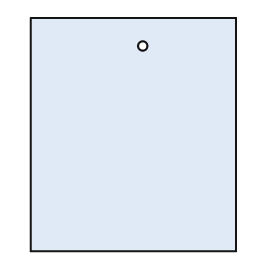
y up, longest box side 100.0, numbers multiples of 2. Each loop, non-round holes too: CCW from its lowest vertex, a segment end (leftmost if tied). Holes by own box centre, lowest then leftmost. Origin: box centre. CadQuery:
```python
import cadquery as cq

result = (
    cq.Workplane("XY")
    .moveTo(-44.0, -50.0)
    .lineTo(44.0, -50.0)
    .lineTo(44.0, 50.0)
    .lineTo(-44.0, 50.0)
    .close()
    .moveTo(4.0, 38.0)
    .circle(2.0)
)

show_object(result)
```